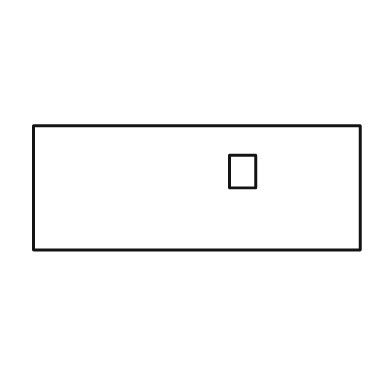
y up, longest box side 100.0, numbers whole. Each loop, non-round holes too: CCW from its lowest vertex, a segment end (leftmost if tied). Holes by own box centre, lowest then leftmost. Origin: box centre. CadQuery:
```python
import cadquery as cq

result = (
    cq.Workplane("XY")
    .moveTo(-50.0, -19.0)
    .lineTo(50.0, -19.0)
    .lineTo(50.0, 19.0)
    .lineTo(-50.0, 19.0)
    .close()
    .moveTo(10.0, 0.0)
    .lineTo(18.0, 0.0)
    .lineTo(18.0, 10.0)
    .lineTo(10.0, 10.0)
    .close()
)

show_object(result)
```